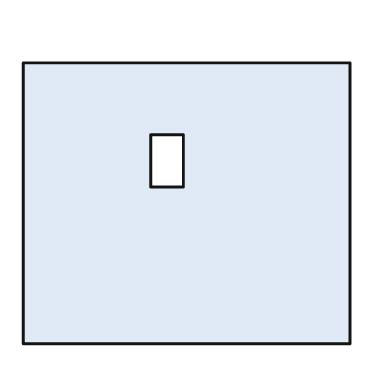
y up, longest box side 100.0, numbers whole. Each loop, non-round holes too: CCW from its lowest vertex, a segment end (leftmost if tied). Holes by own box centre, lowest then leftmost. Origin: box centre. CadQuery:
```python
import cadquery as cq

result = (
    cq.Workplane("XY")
    .moveTo(-50.0, -43.0)
    .lineTo(50.0, -43.0)
    .lineTo(50.0, 43.0)
    .lineTo(-50.0, 43.0)
    .close()
    .moveTo(-11.0, 5.0)
    .lineTo(-1.0, 5.0)
    .lineTo(-1.0, 21.0)
    .lineTo(-11.0, 21.0)
    .close()
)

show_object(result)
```